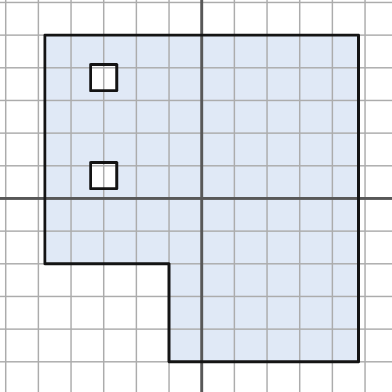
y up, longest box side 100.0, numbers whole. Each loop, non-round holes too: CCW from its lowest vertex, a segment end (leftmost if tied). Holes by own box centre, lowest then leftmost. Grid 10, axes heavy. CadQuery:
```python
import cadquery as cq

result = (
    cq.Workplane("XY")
    .moveTo(-10.0, -50.0)
    .lineTo(48.0, -50.0)
    .lineTo(48.0, 50.0)
    .lineTo(-48.0, 50.0)
    .lineTo(-48.0, -20.0)
    .lineTo(-10.0, -20.0)
    .close()
    .moveTo(-34.0, 3.0)
    .lineTo(-26.0, 3.0)
    .lineTo(-26.0, 11.0)
    .lineTo(-34.0, 11.0)
    .close()
    .moveTo(-34.0, 33.0)
    .lineTo(-26.0, 33.0)
    .lineTo(-26.0, 41.0)
    .lineTo(-34.0, 41.0)
    .close()
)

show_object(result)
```